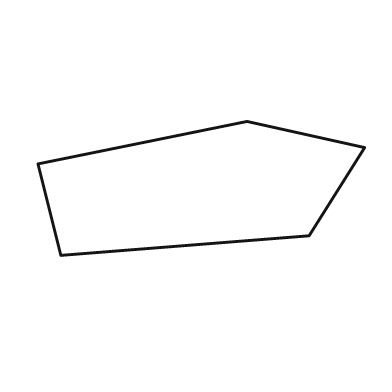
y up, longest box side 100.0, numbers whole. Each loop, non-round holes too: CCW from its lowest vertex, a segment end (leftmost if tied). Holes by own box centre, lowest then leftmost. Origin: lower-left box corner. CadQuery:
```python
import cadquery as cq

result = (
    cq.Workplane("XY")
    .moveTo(7.0, 0.0)
    .lineTo(83.0, 6.0)
    .lineTo(100.0, 33.0)
    .lineTo(64.0, 41.0)
    .lineTo(0.0, 28.0)
    .close()
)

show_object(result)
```